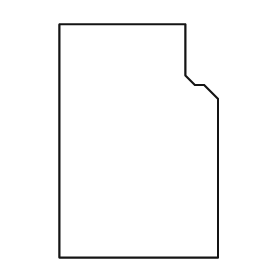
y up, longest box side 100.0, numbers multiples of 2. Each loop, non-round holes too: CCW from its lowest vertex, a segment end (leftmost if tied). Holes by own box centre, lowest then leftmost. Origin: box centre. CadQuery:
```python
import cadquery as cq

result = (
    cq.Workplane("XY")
    .moveTo(-34.0, -50.0)
    .lineTo(34.0, -50.0)
    .lineTo(34.0, 18.0)
    .lineTo(28.0, 24.0)
    .lineTo(24.0, 24.0)
    .lineTo(20.0, 28.0)
    .lineTo(20.0, 50.0)
    .lineTo(-34.0, 50.0)
    .close()
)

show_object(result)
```